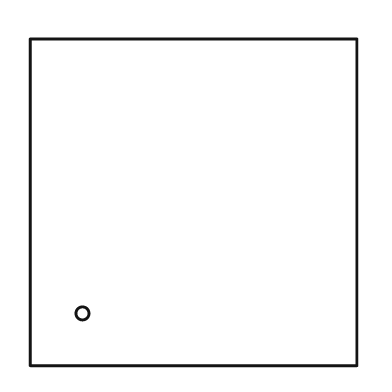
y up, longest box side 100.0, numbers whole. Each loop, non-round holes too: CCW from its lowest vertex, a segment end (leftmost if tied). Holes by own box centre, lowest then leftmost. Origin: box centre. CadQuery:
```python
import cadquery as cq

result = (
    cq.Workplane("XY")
    .moveTo(-50.0, -50.0)
    .lineTo(50.0, -50.0)
    .lineTo(50.0, 50.0)
    .lineTo(-50.0, 50.0)
    .close()
    .moveTo(-34.0, -34.0)
    .circle(2.0)
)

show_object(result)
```